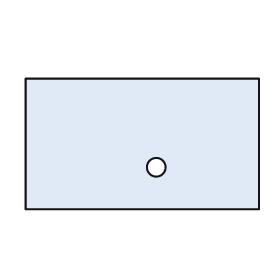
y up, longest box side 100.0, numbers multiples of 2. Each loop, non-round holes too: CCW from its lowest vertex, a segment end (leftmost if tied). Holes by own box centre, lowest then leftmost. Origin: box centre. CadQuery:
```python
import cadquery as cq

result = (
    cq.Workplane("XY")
    .moveTo(-50.0, -28.0)
    .lineTo(50.0, -28.0)
    .lineTo(50.0, 28.0)
    .lineTo(-50.0, 28.0)
    .close()
    .moveTo(6.0, -10.0)
    .circle(4.0)
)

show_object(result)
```